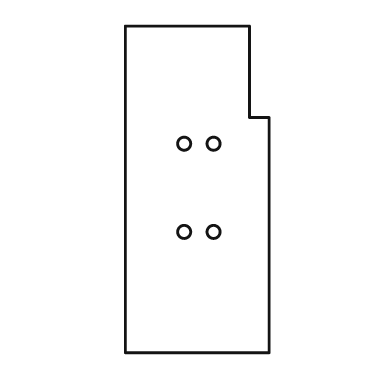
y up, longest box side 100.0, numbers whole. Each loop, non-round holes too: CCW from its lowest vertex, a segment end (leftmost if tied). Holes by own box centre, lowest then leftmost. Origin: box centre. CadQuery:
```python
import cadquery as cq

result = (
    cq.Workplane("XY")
    .moveTo(-22.0, -50.0)
    .lineTo(22.0, -50.0)
    .lineTo(22.0, 22.0)
    .lineTo(16.0, 22.0)
    .lineTo(16.0, 50.0)
    .lineTo(-22.0, 50.0)
    .close()
    .moveTo(-4.0, -13.0)
    .circle(2.0)
    .moveTo(5.0, -13.0)
    .circle(2.0)
    .moveTo(-4.0, 14.0)
    .circle(2.0)
    .moveTo(5.0, 14.0)
    .circle(2.0)
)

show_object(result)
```